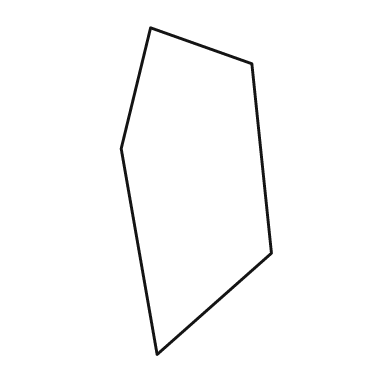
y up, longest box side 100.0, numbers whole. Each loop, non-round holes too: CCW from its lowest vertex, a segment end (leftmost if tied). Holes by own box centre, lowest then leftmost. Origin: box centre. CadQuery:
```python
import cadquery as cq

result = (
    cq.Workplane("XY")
    .moveTo(-12.0, -50.0)
    .lineTo(23.0, -19.0)
    .lineTo(17.0, 39.0)
    .lineTo(-14.0, 50.0)
    .lineTo(-23.0, 13.0)
    .close()
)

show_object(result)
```